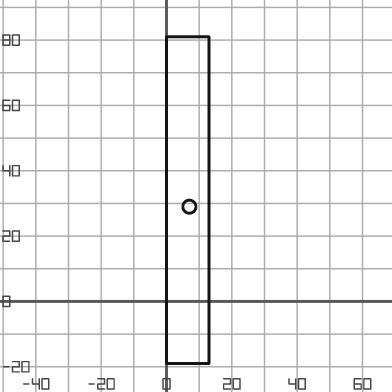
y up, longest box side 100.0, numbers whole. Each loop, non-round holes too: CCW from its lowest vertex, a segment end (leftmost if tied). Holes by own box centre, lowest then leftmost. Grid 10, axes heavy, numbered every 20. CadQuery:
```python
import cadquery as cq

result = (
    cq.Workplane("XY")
    .moveTo(0.0, -19.0)
    .lineTo(13.0, -19.0)
    .lineTo(13.0, 81.0)
    .lineTo(0.0, 81.0)
    .close()
    .moveTo(7.0, 29.0)
    .circle(2.0)
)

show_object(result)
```